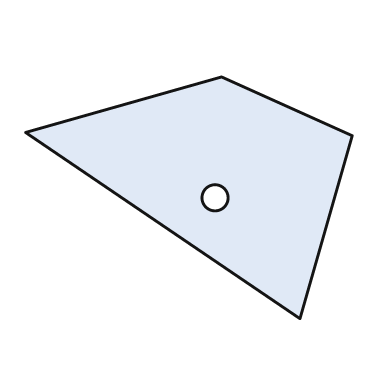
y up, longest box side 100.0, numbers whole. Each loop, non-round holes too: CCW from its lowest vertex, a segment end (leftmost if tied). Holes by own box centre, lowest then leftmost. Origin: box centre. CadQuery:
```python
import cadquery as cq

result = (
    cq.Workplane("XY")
    .moveTo(34.0, -37.0)
    .lineTo(50.0, 19.0)
    .lineTo(10.0, 37.0)
    .lineTo(-50.0, 20.0)
    .close()
    .moveTo(8.0, 0.0)
    .circle(4.0)
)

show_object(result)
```